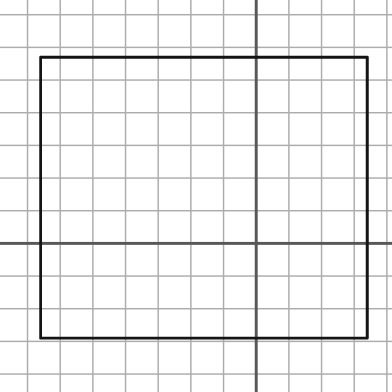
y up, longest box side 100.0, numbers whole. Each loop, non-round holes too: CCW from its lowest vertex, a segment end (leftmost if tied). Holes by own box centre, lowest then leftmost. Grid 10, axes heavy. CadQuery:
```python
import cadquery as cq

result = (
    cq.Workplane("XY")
    .moveTo(-66.0, -29.0)
    .lineTo(34.0, -29.0)
    .lineTo(34.0, 57.0)
    .lineTo(-66.0, 57.0)
    .close()
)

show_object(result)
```